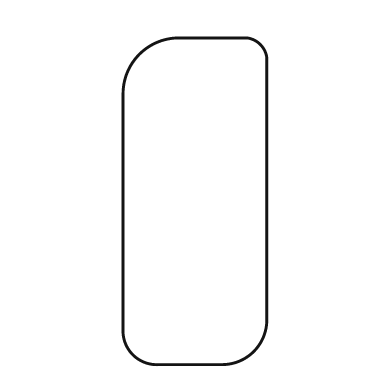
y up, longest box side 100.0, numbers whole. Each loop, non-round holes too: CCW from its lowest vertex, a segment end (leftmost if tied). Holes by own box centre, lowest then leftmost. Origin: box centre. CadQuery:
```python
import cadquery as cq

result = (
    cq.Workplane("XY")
    .moveTo(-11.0, -50.0)
    .lineTo(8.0, -50.0)
    .threePointArc((18.0, -46.0), (22.0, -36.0))
    .lineTo(22.0, 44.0)
    .threePointArc((20.0, 48.0), (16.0, 50.0))
    .lineTo(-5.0, 50.0)
    .threePointArc((-17.0, 45.0), (-22.0, 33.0))
    .lineTo(-22.0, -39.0)
    .threePointArc((-19.0, -47.0), (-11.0, -50.0))
    .close()
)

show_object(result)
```